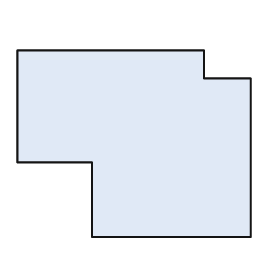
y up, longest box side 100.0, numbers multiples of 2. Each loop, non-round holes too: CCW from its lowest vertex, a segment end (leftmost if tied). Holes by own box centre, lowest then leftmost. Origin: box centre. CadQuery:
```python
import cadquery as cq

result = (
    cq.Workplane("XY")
    .moveTo(-18.0, -40.0)
    .lineTo(50.0, -40.0)
    .lineTo(50.0, 28.0)
    .lineTo(30.0, 28.0)
    .lineTo(30.0, 40.0)
    .lineTo(-50.0, 40.0)
    .lineTo(-50.0, -8.0)
    .lineTo(-18.0, -8.0)
    .close()
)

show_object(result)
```